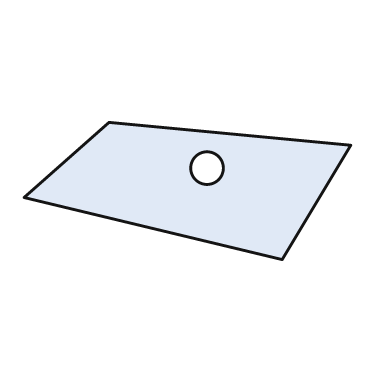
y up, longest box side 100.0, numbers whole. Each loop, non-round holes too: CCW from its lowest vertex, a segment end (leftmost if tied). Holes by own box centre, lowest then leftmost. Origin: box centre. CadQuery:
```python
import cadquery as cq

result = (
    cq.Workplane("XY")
    .moveTo(29.0, -21.0)
    .lineTo(50.0, 14.0)
    .lineTo(-24.0, 21.0)
    .lineTo(-50.0, -2.0)
    .close()
    .moveTo(6.0, 7.0)
    .circle(5.0)
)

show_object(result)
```